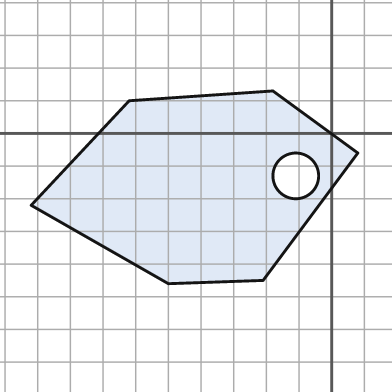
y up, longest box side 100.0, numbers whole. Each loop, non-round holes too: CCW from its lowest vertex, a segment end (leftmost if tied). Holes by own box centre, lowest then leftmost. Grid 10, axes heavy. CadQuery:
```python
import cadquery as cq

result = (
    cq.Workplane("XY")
    .moveTo(-50.0, -46.0)
    .lineTo(-21.0, -45.0)
    .lineTo(8.0, -6.0)
    .lineTo(-18.0, 13.0)
    .lineTo(-62.0, 10.0)
    .lineTo(-92.0, -22.0)
    .close()
    .moveTo(-11.0, -13.0)
    .circle(7.0)
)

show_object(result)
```